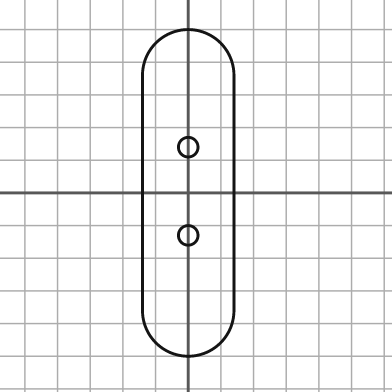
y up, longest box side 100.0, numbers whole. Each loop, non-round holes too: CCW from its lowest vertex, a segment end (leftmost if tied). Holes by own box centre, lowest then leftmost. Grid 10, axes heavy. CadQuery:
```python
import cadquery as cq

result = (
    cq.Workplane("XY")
    .moveTo(-14.0, -36.0)
    .threePointArc((0.0, -50.0), (14.0, -36.0))
    .lineTo(14.0, 36.0)
    .threePointArc((0.0, 50.0), (-14.0, 36.0))
    .close()
    .moveTo(0.0, -13.0)
    .circle(3.0)
    .moveTo(0.0, 14.0)
    .circle(3.0)
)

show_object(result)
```